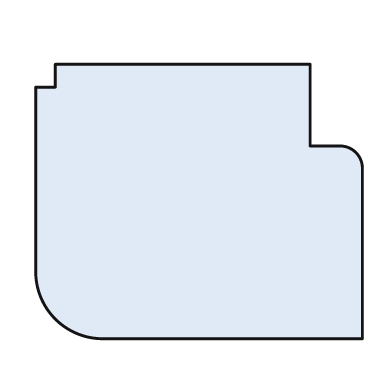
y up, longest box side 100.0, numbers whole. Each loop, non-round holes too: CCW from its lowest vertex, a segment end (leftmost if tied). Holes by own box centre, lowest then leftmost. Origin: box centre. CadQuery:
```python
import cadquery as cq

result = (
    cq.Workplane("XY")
    .moveTo(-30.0, -42.0)
    .lineTo(50.0, -42.0)
    .lineTo(50.0, 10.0)
    .threePointArc((48.0, 15.0), (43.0, 17.0))
    .lineTo(34.0, 17.0)
    .lineTo(34.0, 42.0)
    .lineTo(-44.0, 42.0)
    .lineTo(-44.0, 35.0)
    .lineTo(-50.0, 35.0)
    .lineTo(-50.0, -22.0)
    .threePointArc((-44.0, -36.0), (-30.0, -42.0))
    .close()
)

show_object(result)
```